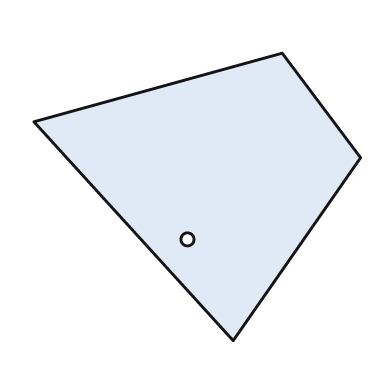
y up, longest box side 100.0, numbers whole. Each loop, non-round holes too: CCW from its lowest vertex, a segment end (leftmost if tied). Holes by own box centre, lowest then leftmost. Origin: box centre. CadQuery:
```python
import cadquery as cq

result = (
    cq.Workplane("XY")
    .moveTo(11.0, -44.0)
    .lineTo(50.0, 12.0)
    .lineTo(26.0, 44.0)
    .lineTo(-50.0, 23.0)
    .close()
    .moveTo(-3.0, -13.0)
    .circle(2.0)
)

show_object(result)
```